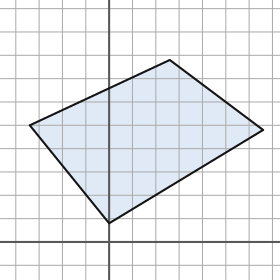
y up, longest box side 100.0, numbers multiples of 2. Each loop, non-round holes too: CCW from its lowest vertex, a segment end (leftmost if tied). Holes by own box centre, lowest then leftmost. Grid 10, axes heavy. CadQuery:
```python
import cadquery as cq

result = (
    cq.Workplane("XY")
    .moveTo(0.0, 8.0)
    .lineTo(66.0, 48.0)
    .lineTo(26.0, 78.0)
    .lineTo(-34.0, 50.0)
    .close()
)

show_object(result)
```